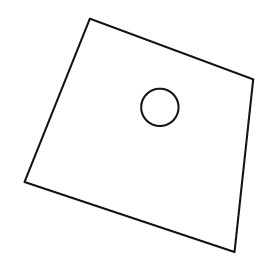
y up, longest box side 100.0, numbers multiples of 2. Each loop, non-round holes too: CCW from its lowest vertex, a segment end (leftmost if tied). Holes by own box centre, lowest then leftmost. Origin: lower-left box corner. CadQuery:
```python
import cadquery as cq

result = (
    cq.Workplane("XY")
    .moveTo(90.0, 0.0)
    .lineTo(98.0, 74.0)
    .lineTo(28.0, 100.0)
    .lineTo(0.0, 30.0)
    .close()
    .moveTo(58.0, 62.0)
    .circle(8.0)
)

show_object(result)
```